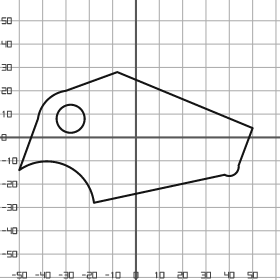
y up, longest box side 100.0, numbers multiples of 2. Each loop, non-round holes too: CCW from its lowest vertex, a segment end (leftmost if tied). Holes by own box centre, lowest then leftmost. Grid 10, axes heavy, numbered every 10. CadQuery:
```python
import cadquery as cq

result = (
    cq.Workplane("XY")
    .moveTo(-18.0, -28.0)
    .lineTo(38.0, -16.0)
    .threePointArc((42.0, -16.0), (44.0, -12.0))
    .lineTo(50.0, 4.0)
    .lineTo(-8.0, 28.0)
    .lineTo(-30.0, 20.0)
    .threePointArc((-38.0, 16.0), (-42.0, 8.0))
    .lineTo(-50.0, -14.0)
    .threePointArc((-30.0, -12.0), (-18.0, -28.0))
    .close()
    .moveTo(-28.0, 8.0)
    .circle(6.0)
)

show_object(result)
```